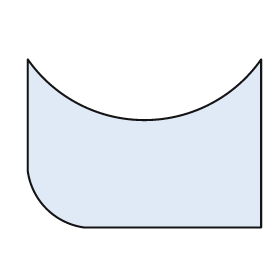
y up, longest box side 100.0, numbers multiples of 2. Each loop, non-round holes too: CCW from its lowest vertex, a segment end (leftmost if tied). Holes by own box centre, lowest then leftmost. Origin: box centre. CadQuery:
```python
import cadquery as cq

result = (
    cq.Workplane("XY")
    .moveTo(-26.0, -36.0)
    .lineTo(50.0, -36.0)
    .lineTo(50.0, 36.0)
    .threePointArc((0.0, 10.0), (-50.0, 36.0))
    .lineTo(-50.0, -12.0)
    .threePointArc((-42.0, -28.0), (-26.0, -36.0))
    .close()
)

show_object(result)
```